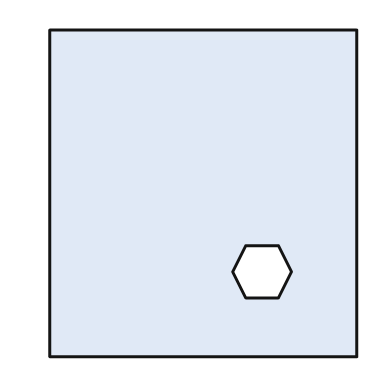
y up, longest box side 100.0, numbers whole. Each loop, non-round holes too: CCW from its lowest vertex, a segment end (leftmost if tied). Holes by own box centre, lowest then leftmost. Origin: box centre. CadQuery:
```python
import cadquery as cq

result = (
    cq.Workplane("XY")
    .moveTo(-47.0, -50.0)
    .lineTo(47.0, -50.0)
    .lineTo(47.0, 50.0)
    .lineTo(-47.0, 50.0)
    .close()
    .moveTo(13.0, -32.0)
    .lineTo(23.0, -32.0)
    .lineTo(27.0, -24.0)
    .lineTo(23.0, -16.0)
    .lineTo(13.0, -16.0)
    .lineTo(9.0, -24.0)
    .close()
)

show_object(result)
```